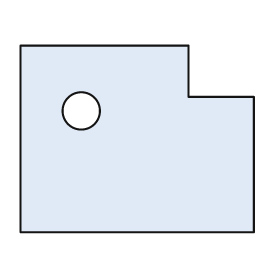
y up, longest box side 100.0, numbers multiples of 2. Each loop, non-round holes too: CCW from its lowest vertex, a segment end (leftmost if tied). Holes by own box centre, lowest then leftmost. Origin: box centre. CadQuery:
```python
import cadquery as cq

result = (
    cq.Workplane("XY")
    .moveTo(-50.0, -40.0)
    .lineTo(50.0, -40.0)
    .lineTo(50.0, 18.0)
    .lineTo(22.0, 18.0)
    .lineTo(22.0, 40.0)
    .lineTo(-50.0, 40.0)
    .close()
    .moveTo(-24.0, 12.0)
    .circle(8.0)
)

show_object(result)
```